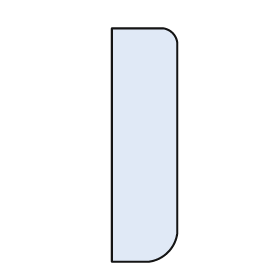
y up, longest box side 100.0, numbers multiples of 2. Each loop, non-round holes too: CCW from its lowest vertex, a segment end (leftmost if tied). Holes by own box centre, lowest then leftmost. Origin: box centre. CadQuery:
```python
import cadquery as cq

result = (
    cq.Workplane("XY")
    .moveTo(-14.0, -50.0)
    .lineTo(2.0, -50.0)
    .threePointArc((10.0, -46.0), (14.0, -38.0))
    .lineTo(14.0, 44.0)
    .threePointArc((12.0, 48.0), (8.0, 50.0))
    .lineTo(-14.0, 50.0)
    .close()
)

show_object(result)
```